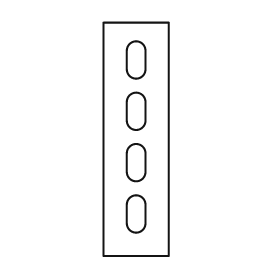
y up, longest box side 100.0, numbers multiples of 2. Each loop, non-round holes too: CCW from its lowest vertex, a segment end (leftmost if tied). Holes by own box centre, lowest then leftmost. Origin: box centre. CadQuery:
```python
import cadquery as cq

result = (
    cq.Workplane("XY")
    .moveTo(-14.0, -50.0)
    .lineTo(14.0, -50.0)
    .lineTo(14.0, 50.0)
    .lineTo(-14.0, 50.0)
    .close()
    .moveTo(-4.0, -36.0)
    .threePointArc((0.0, -40.0), (4.0, -36.0))
    .lineTo(4.0, -28.0)
    .threePointArc((0.0, -24.0), (-4.0, -28.0))
    .close()
    .moveTo(-4.0, -14.0)
    .threePointArc((0.0, -18.0), (4.0, -14.0))
    .lineTo(4.0, -6.0)
    .threePointArc((0.0, -2.0), (-4.0, -6.0))
    .close()
    .moveTo(-4.0, 8.0)
    .threePointArc((0.0, 4.0), (4.0, 8.0))
    .lineTo(4.0, 16.0)
    .threePointArc((0.0, 20.0), (-4.0, 16.0))
    .close()
    .moveTo(-4.0, 30.0)
    .threePointArc((0.0, 26.0), (4.0, 30.0))
    .lineTo(4.0, 38.0)
    .threePointArc((0.0, 42.0), (-4.0, 38.0))
    .close()
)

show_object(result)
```